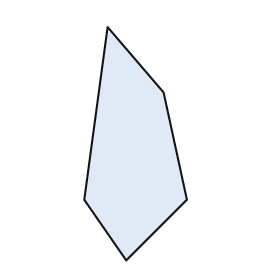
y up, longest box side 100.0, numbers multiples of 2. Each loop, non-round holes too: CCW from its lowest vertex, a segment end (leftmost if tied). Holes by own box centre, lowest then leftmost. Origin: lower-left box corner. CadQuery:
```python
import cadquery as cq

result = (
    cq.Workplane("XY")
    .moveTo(18.0, 0.0)
    .lineTo(44.0, 26.0)
    .lineTo(34.0, 72.0)
    .lineTo(10.0, 100.0)
    .lineTo(0.0, 26.0)
    .close()
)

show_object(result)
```